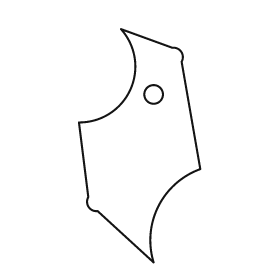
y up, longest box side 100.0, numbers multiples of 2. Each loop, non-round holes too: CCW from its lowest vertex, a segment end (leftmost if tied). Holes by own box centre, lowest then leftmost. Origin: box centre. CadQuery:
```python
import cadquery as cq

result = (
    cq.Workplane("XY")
    .moveTo(6.0, -50.0)
    .threePointArc((8.0, -26.0), (26.0, -10.0))
    .lineTo(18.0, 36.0)
    .threePointArc((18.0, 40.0), (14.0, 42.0))
    .lineTo(-8.0, 50.0)
    .threePointArc((-4.0, 24.0), (-26.0, 10.0))
    .lineTo(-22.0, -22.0)
    .threePointArc((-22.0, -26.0), (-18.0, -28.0))
    .close()
    .moveTo(6.0, 22.0)
    .circle(4.0)
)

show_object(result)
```